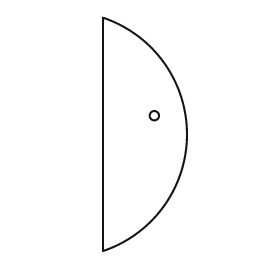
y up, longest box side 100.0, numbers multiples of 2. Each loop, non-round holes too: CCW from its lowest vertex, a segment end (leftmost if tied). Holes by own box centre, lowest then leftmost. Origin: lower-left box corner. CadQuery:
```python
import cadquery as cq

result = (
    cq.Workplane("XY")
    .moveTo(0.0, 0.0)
    .threePointArc((36.0, 50.0), (0.0, 100.0))
    .close()
    .moveTo(22.0, 58.0)
    .circle(2.0)
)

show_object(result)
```